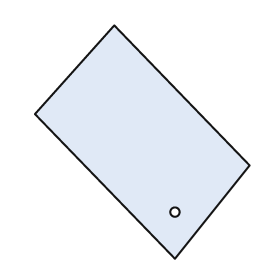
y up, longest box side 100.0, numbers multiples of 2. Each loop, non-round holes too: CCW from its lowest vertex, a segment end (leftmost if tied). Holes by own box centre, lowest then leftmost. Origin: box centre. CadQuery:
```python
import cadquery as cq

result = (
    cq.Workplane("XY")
    .moveTo(14.0, -50.0)
    .lineTo(46.0, -10.0)
    .lineTo(-12.0, 50.0)
    .lineTo(-46.0, 12.0)
    .close()
    .moveTo(14.0, -30.0)
    .circle(2.0)
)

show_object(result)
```